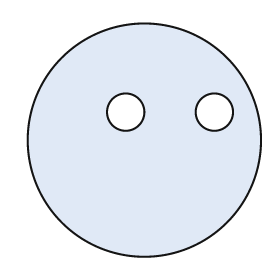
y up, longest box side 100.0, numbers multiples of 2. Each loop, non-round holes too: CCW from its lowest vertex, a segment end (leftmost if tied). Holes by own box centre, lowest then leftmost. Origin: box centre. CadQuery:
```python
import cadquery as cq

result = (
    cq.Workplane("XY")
    .moveTo(0.0, 0.0)
    .circle(50.0)
    .moveTo(-8.0, 12.0)
    .circle(8.0)
    .moveTo(30.0, 12.0)
    .circle(8.0)
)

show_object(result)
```